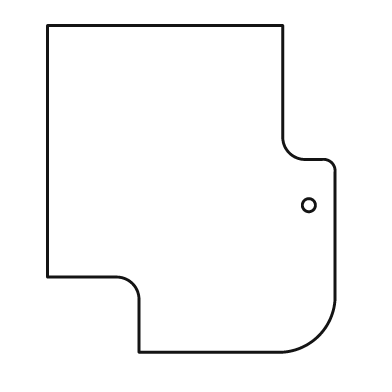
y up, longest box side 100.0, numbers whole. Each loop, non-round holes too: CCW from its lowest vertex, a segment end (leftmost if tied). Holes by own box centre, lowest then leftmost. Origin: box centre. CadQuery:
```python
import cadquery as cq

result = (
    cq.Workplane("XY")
    .moveTo(-16.0, -50.0)
    .lineTo(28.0, -50.0)
    .threePointArc((39.0, -45.0), (44.0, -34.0))
    .lineTo(44.0, 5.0)
    .threePointArc((43.0, 8.0), (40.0, 9.0))
    .lineTo(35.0, 9.0)
    .threePointArc((30.0, 11.0), (28.0, 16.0))
    .lineTo(28.0, 50.0)
    .lineTo(-44.0, 50.0)
    .lineTo(-44.0, -27.0)
    .lineTo(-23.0, -27.0)
    .threePointArc((-18.0, -29.0), (-16.0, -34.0))
    .close()
    .moveTo(36.0, -5.0)
    .circle(2.0)
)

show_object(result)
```